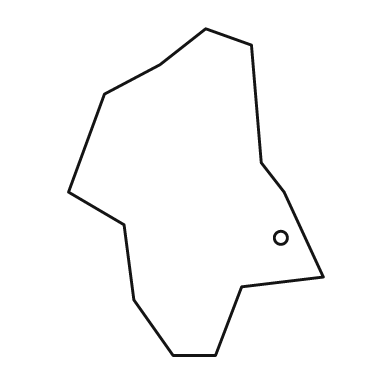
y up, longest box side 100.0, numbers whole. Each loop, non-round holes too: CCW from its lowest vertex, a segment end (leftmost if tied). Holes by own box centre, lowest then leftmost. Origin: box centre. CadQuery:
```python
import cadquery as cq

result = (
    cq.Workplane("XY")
    .moveTo(-7.0, -50.0)
    .lineTo(6.0, -50.0)
    .lineTo(14.0, -29.0)
    .lineTo(39.0, -26.0)
    .lineTo(27.0, 0.0)
    .lineTo(20.0, 9.0)
    .lineTo(17.0, 45.0)
    .lineTo(3.0, 50.0)
    .lineTo(-11.0, 39.0)
    .lineTo(-28.0, 30.0)
    .lineTo(-39.0, 0.0)
    .lineTo(-22.0, -10.0)
    .lineTo(-19.0, -33.0)
    .close()
    .moveTo(26.0, -14.0)
    .circle(2.0)
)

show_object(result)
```